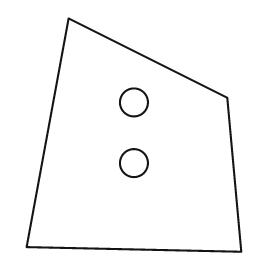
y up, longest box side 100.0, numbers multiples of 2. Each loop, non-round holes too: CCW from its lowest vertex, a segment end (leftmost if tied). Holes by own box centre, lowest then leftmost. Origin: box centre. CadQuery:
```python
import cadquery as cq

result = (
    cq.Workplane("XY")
    .moveTo(46.0, -50.0)
    .lineTo(40.0, 16.0)
    .lineTo(-28.0, 50.0)
    .lineTo(-46.0, -48.0)
    .close()
    .moveTo(0.0, -12.0)
    .circle(6.0)
    .moveTo(0.0, 14.0)
    .circle(6.0)
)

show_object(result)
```